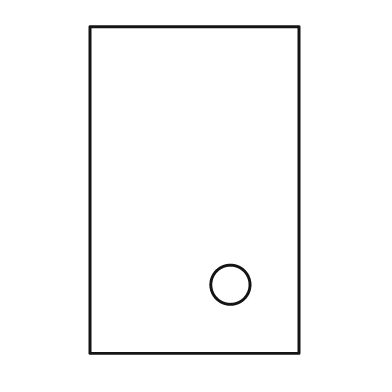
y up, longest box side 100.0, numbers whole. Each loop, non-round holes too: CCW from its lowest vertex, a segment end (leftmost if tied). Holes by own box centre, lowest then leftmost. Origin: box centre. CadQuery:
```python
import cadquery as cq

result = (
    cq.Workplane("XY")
    .moveTo(-32.0, -50.0)
    .lineTo(32.0, -50.0)
    .lineTo(32.0, 50.0)
    .lineTo(-32.0, 50.0)
    .close()
    .moveTo(11.0, -29.0)
    .circle(6.0)
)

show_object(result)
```